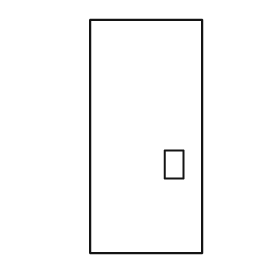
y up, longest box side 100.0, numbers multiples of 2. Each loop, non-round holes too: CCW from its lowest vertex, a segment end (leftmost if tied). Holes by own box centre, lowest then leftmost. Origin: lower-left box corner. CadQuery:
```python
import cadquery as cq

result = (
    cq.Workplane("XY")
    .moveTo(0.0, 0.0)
    .lineTo(48.0, 0.0)
    .lineTo(48.0, 100.0)
    .lineTo(0.0, 100.0)
    .close()
    .moveTo(32.0, 32.0)
    .lineTo(40.0, 32.0)
    .lineTo(40.0, 44.0)
    .lineTo(32.0, 44.0)
    .close()
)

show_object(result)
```